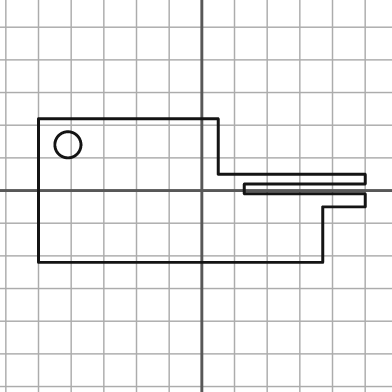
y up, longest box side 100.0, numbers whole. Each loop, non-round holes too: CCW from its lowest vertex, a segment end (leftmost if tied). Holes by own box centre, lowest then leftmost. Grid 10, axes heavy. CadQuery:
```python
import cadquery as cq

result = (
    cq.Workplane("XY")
    .moveTo(-50.0, -22.0)
    .lineTo(37.0, -22.0)
    .lineTo(37.0, -5.0)
    .lineTo(50.0, -5.0)
    .lineTo(50.0, -1.0)
    .lineTo(13.0, -1.0)
    .lineTo(13.0, 2.0)
    .lineTo(50.0, 2.0)
    .lineTo(50.0, 5.0)
    .lineTo(5.0, 5.0)
    .lineTo(5.0, 22.0)
    .lineTo(-50.0, 22.0)
    .close()
    .moveTo(-41.0, 14.0)
    .circle(4.0)
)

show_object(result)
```